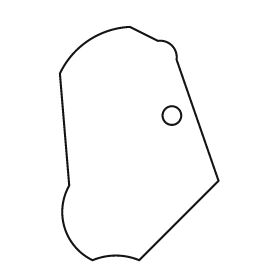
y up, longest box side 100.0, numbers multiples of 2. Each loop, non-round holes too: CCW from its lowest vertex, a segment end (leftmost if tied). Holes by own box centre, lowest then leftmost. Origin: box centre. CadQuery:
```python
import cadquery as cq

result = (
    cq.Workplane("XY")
    .moveTo(-20.0, -50.0)
    .threePointArc((-10.0, -48.0), (0.0, -50.0))
    .lineTo(34.0, -16.0)
    .lineTo(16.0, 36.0)
    .threePointArc((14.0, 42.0), (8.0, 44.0))
    .lineTo(-4.0, 50.0)
    .threePointArc((-22.0, 44.0), (-34.0, 30.0))
    .lineTo(-30.0, -18.0)
    .threePointArc((-32.0, -36.0), (-20.0, -50.0))
    .close()
    .moveTo(14.0, 12.0)
    .circle(4.0)
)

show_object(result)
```